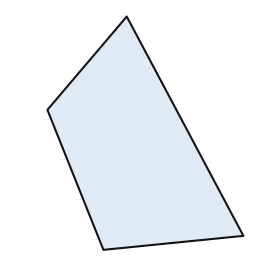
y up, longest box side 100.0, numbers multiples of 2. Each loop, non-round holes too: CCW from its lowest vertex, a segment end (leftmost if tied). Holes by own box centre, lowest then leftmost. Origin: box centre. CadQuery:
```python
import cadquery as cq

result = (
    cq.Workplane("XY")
    .moveTo(-18.0, -50.0)
    .lineTo(42.0, -44.0)
    .lineTo(-8.0, 50.0)
    .lineTo(-42.0, 10.0)
    .close()
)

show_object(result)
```